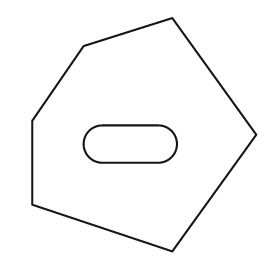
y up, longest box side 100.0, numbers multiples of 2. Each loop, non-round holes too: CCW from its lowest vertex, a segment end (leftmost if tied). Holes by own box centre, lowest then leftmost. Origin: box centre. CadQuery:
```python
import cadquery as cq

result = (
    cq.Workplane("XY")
    .moveTo(12.0, -50.0)
    .lineTo(48.0, 0.0)
    .lineTo(12.0, 50.0)
    .lineTo(-26.0, 38.0)
    .lineTo(-48.0, 6.0)
    .lineTo(-48.0, -30.0)
    .close()
    .moveTo(-18.0, -12.0)
    .lineTo(6.0, -12.0)
    .threePointArc((14.0, -4.0), (6.0, 4.0))
    .lineTo(-18.0, 4.0)
    .threePointArc((-26.0, -4.0), (-18.0, -12.0))
    .close()
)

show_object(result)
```